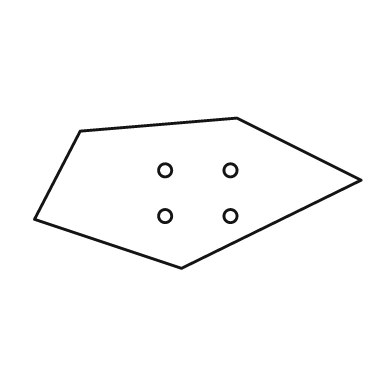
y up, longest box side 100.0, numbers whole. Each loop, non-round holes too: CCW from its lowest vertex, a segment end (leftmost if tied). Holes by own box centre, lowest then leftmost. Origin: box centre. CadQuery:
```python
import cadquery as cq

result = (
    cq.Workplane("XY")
    .moveTo(-5.0, -23.0)
    .lineTo(50.0, 4.0)
    .lineTo(12.0, 23.0)
    .lineTo(-36.0, 19.0)
    .lineTo(-50.0, -8.0)
    .close()
    .moveTo(-10.0, -7.0)
    .circle(2.0)
    .moveTo(10.0, -7.0)
    .circle(2.0)
    .moveTo(-10.0, 7.0)
    .circle(2.0)
    .moveTo(10.0, 7.0)
    .circle(2.0)
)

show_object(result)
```